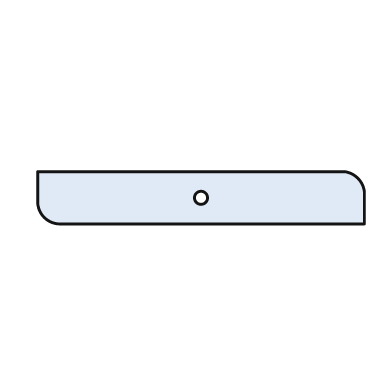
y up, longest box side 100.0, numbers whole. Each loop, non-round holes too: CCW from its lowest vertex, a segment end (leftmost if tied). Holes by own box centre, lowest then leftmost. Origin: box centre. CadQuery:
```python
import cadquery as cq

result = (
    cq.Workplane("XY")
    .moveTo(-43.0, -8.0)
    .lineTo(50.0, -8.0)
    .lineTo(50.0, 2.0)
    .threePointArc((48.0, 6.0), (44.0, 8.0))
    .lineTo(-50.0, 8.0)
    .lineTo(-50.0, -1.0)
    .threePointArc((-48.0, -6.0), (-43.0, -8.0))
    .close()
    .moveTo(0.0, 0.0)
    .circle(2.0)
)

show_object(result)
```